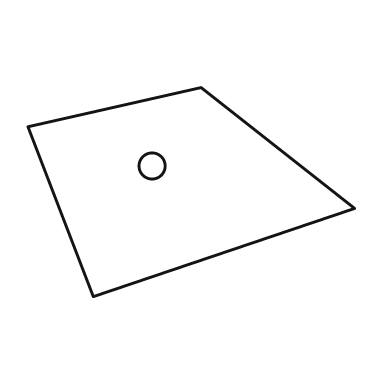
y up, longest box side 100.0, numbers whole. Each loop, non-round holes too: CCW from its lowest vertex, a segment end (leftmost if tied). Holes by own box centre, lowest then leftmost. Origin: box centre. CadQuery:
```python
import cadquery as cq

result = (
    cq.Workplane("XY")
    .moveTo(-30.0, -32.0)
    .lineTo(50.0, -5.0)
    .lineTo(3.0, 32.0)
    .lineTo(-50.0, 20.0)
    .close()
    .moveTo(-12.0, 8.0)
    .circle(4.0)
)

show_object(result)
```